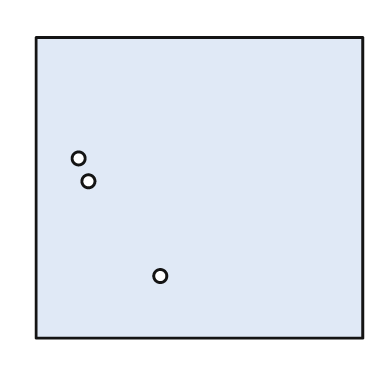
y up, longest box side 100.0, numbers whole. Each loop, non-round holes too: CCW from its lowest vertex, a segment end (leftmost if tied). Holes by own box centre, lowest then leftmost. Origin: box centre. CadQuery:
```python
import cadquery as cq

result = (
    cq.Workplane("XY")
    .moveTo(-50.0, -46.0)
    .lineTo(50.0, -46.0)
    .lineTo(50.0, 46.0)
    .lineTo(-50.0, 46.0)
    .close()
    .moveTo(-12.0, -27.0)
    .circle(2.0)
    .moveTo(-34.0, 2.0)
    .circle(2.0)
    .moveTo(-37.0, 9.0)
    .circle(2.0)
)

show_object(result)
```